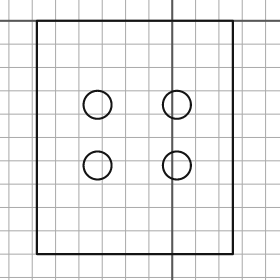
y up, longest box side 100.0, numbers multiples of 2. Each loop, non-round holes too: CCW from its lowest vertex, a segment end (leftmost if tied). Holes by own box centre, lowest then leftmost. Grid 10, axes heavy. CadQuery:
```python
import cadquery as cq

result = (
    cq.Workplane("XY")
    .moveTo(-58.0, -100.0)
    .lineTo(26.0, -100.0)
    .lineTo(26.0, 0.0)
    .lineTo(-58.0, 0.0)
    .close()
    .moveTo(-32.0, -62.0)
    .circle(6.0)
    .moveTo(2.0, -62.0)
    .circle(6.0)
    .moveTo(-32.0, -36.0)
    .circle(6.0)
    .moveTo(2.0, -36.0)
    .circle(6.0)
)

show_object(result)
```